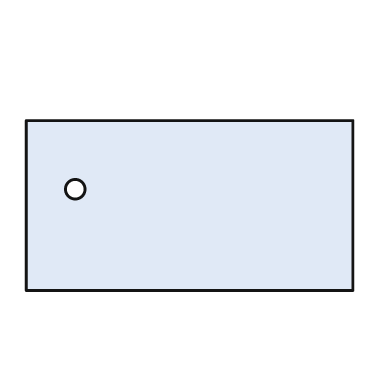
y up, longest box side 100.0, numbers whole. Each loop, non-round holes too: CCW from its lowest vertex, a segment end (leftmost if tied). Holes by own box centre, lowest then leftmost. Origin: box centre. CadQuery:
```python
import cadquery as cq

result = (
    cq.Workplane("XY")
    .moveTo(-50.0, -26.0)
    .lineTo(50.0, -26.0)
    .lineTo(50.0, 26.0)
    .lineTo(-50.0, 26.0)
    .close()
    .moveTo(-35.0, 5.0)
    .circle(3.0)
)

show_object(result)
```